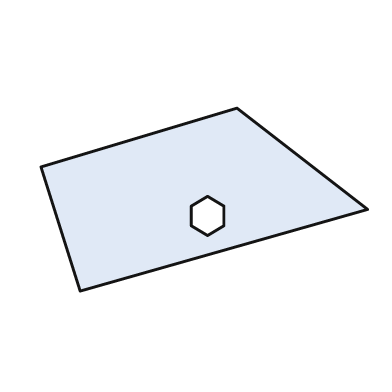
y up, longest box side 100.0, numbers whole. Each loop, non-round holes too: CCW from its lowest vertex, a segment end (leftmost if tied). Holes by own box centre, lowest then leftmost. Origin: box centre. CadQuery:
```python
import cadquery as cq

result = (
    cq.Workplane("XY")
    .moveTo(-38.0, -28.0)
    .lineTo(50.0, -3.0)
    .lineTo(10.0, 28.0)
    .lineTo(-50.0, 10.0)
    .close()
    .moveTo(1.0, -11.0)
    .lineTo(6.0, -8.0)
    .lineTo(6.0, -2.0)
    .lineTo(1.0, 1.0)
    .lineTo(-4.0, -2.0)
    .lineTo(-4.0, -8.0)
    .close()
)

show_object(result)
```